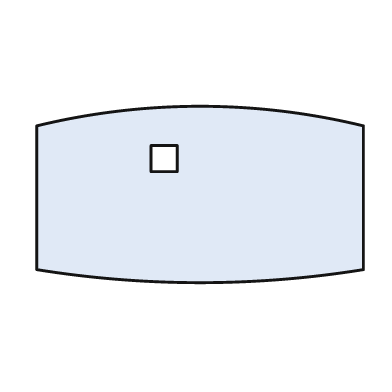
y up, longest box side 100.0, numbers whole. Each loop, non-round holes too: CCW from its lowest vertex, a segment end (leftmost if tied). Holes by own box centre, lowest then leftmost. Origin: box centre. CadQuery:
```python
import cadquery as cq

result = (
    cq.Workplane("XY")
    .moveTo(-50.0, -23.0)
    .threePointArc((0.0, -27.0), (50.0, -23.0))
    .lineTo(50.0, 21.0)
    .threePointArc((0.0, 27.0), (-50.0, 21.0))
    .close()
    .moveTo(-15.0, 7.0)
    .lineTo(-7.0, 7.0)
    .lineTo(-7.0, 15.0)
    .lineTo(-15.0, 15.0)
    .close()
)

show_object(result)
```